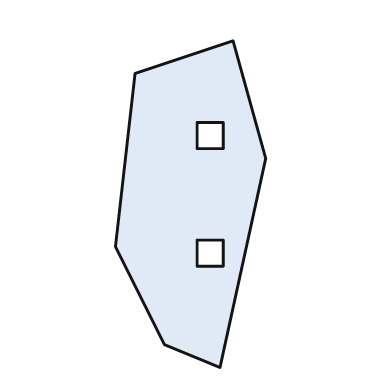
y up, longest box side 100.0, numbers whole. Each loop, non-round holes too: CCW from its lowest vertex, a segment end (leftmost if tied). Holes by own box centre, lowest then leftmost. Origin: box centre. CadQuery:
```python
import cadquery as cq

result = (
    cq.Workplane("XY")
    .moveTo(9.0, -50.0)
    .lineTo(23.0, 14.0)
    .lineTo(13.0, 50.0)
    .lineTo(-17.0, 40.0)
    .lineTo(-23.0, -13.0)
    .lineTo(-8.0, -43.0)
    .close()
    .moveTo(2.0, -19.0)
    .lineTo(10.0, -19.0)
    .lineTo(10.0, -11.0)
    .lineTo(2.0, -11.0)
    .close()
    .moveTo(2.0, 17.0)
    .lineTo(10.0, 17.0)
    .lineTo(10.0, 25.0)
    .lineTo(2.0, 25.0)
    .close()
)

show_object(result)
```